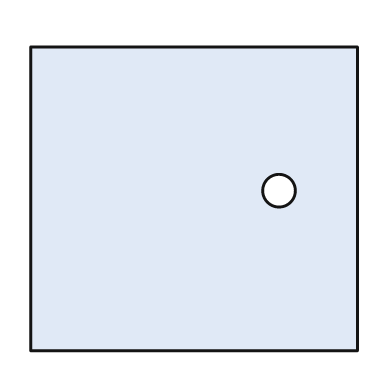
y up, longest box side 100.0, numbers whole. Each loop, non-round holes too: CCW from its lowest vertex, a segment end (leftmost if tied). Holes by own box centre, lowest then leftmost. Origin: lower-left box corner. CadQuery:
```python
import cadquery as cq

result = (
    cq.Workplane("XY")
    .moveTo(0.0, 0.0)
    .lineTo(100.0, 0.0)
    .lineTo(100.0, 93.0)
    .lineTo(0.0, 93.0)
    .close()
    .moveTo(76.0, 49.0)
    .circle(5.0)
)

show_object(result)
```